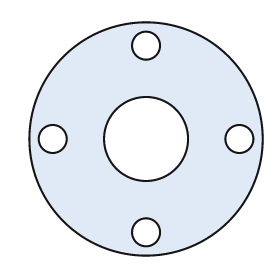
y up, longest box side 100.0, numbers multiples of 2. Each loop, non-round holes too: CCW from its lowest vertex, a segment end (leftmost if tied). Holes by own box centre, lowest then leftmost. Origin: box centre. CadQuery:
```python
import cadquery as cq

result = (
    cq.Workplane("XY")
    .moveTo(0.0, 0.0)
    .circle(50.0)
    .moveTo(0.0, -40.0)
    .circle(6.0)
    .moveTo(-40.0, 0.0)
    .circle(6.0)
    .moveTo(0.0, 0.0)
    .circle(18.0)
    .moveTo(40.0, 0.0)
    .circle(6.0)
    .moveTo(0.0, 40.0)
    .circle(6.0)
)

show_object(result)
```